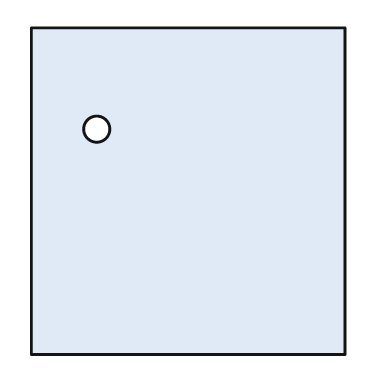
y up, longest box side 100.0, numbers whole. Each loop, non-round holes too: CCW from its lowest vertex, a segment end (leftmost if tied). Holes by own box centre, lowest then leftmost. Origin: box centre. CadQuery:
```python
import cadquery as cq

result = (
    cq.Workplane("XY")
    .moveTo(-48.0, -50.0)
    .lineTo(48.0, -50.0)
    .lineTo(48.0, 50.0)
    .lineTo(-48.0, 50.0)
    .close()
    .moveTo(-28.0, 19.0)
    .circle(4.0)
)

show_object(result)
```